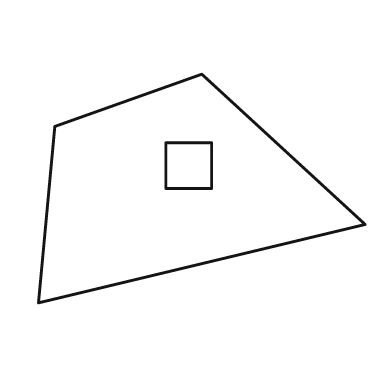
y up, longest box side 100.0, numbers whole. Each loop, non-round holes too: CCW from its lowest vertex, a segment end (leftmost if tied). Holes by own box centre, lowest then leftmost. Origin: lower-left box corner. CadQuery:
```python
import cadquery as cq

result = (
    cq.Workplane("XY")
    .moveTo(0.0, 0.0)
    .lineTo(100.0, 24.0)
    .lineTo(50.0, 70.0)
    .lineTo(5.0, 54.0)
    .close()
    .moveTo(39.0, 35.0)
    .lineTo(53.0, 35.0)
    .lineTo(53.0, 49.0)
    .lineTo(39.0, 49.0)
    .close()
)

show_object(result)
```